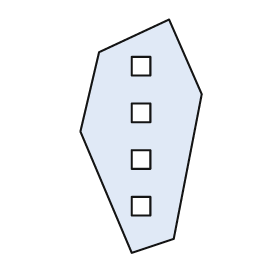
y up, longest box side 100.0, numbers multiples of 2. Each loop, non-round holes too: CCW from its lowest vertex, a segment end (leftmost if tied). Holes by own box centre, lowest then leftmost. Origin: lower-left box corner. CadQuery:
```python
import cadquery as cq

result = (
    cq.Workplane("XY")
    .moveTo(22.0, 0.0)
    .lineTo(40.0, 6.0)
    .lineTo(52.0, 68.0)
    .lineTo(38.0, 100.0)
    .lineTo(8.0, 86.0)
    .lineTo(0.0, 52.0)
    .close()
    .moveTo(22.0, 16.0)
    .lineTo(30.0, 16.0)
    .lineTo(30.0, 24.0)
    .lineTo(22.0, 24.0)
    .close()
    .moveTo(22.0, 36.0)
    .lineTo(30.0, 36.0)
    .lineTo(30.0, 44.0)
    .lineTo(22.0, 44.0)
    .close()
    .moveTo(22.0, 56.0)
    .lineTo(30.0, 56.0)
    .lineTo(30.0, 64.0)
    .lineTo(22.0, 64.0)
    .close()
    .moveTo(22.0, 76.0)
    .lineTo(30.0, 76.0)
    .lineTo(30.0, 84.0)
    .lineTo(22.0, 84.0)
    .close()
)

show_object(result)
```